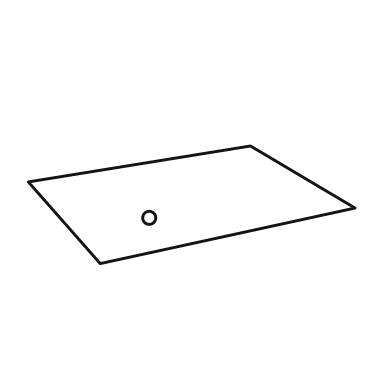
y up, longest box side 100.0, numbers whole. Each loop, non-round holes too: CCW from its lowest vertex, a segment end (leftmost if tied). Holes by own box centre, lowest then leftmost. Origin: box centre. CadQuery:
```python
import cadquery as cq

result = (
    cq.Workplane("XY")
    .moveTo(-28.0, -18.0)
    .lineTo(50.0, -1.0)
    .lineTo(18.0, 18.0)
    .lineTo(-50.0, 7.0)
    .close()
    .moveTo(-13.0, -4.0)
    .circle(2.0)
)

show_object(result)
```